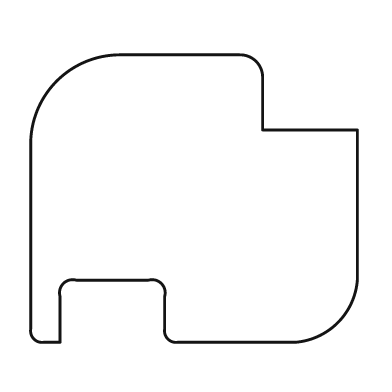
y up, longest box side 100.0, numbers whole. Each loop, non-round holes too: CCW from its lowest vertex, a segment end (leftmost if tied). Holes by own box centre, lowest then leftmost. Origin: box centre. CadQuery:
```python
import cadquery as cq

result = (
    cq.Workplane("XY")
    .moveTo(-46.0, -44.0)
    .lineTo(-41.0, -44.0)
    .lineTo(-41.0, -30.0)
    .threePointArc((-40.0, -26.0), (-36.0, -25.0))
    .lineTo(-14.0, -25.0)
    .threePointArc((-10.0, -26.0), (-9.0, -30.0))
    .lineTo(-9.0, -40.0)
    .threePointArc((-8.0, -43.0), (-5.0, -44.0))
    .lineTo(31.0, -44.0)
    .threePointArc((44.0, -38.0), (50.0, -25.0))
    .lineTo(50.0, 21.0)
    .lineTo(21.0, 21.0)
    .lineTo(21.0, 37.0)
    .threePointArc((19.0, 42.0), (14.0, 44.0))
    .lineTo(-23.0, 44.0)
    .threePointArc((-42.0, 36.0), (-50.0, 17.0))
    .lineTo(-50.0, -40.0)
    .threePointArc((-49.0, -43.0), (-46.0, -44.0))
    .close()
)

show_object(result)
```